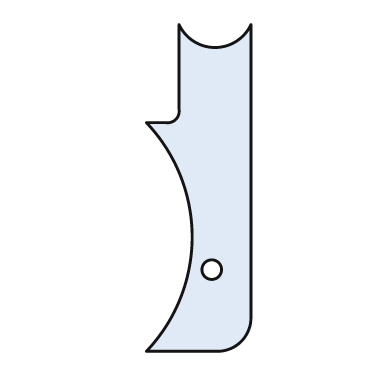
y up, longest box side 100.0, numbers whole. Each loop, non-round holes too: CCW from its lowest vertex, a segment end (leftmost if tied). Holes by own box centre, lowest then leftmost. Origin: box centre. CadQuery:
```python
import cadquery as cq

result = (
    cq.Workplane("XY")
    .moveTo(-16.0, -50.0)
    .lineTo(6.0, -50.0)
    .threePointArc((13.0, -47.0), (16.0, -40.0))
    .lineTo(16.0, 50.0)
    .threePointArc((5.0, 43.0), (-6.0, 50.0))
    .lineTo(-6.0, 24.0)
    .threePointArc((-7.0, 21.0), (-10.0, 20.0))
    .lineTo(-16.0, 20.0)
    .threePointArc((-2.0, -15.0), (-16.0, -50.0))
    .close()
    .moveTo(4.0, -25.0)
    .circle(3.0)
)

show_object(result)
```